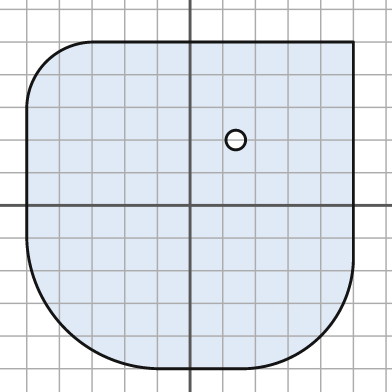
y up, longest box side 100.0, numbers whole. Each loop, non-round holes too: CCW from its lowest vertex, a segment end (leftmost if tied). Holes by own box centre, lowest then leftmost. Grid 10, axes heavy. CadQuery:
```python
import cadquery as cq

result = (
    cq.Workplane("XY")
    .moveTo(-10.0, -50.0)
    .lineTo(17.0, -50.0)
    .threePointArc((40.0, -40.0), (50.0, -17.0))
    .lineTo(50.0, 50.0)
    .lineTo(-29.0, 50.0)
    .threePointArc((-44.0, 44.0), (-50.0, 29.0))
    .lineTo(-50.0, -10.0)
    .threePointArc((-38.0, -38.0), (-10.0, -50.0))
    .close()
    .moveTo(14.0, 20.0)
    .circle(3.0)
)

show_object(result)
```